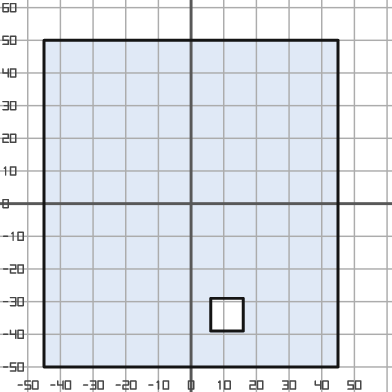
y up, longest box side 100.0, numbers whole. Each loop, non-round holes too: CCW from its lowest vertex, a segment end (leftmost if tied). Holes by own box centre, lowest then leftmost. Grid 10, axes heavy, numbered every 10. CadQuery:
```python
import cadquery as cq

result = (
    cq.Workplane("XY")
    .moveTo(-45.0, -50.0)
    .lineTo(45.0, -50.0)
    .lineTo(45.0, 50.0)
    .lineTo(-45.0, 50.0)
    .close()
    .moveTo(6.0, -39.0)
    .lineTo(16.0, -39.0)
    .lineTo(16.0, -29.0)
    .lineTo(6.0, -29.0)
    .close()
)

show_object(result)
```